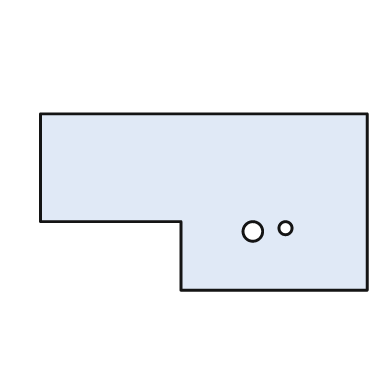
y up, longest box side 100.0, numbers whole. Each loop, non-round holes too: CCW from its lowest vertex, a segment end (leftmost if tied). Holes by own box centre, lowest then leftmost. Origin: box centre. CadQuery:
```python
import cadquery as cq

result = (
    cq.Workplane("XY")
    .moveTo(-7.0, -27.0)
    .lineTo(50.0, -27.0)
    .lineTo(50.0, 27.0)
    .lineTo(-50.0, 27.0)
    .lineTo(-50.0, -6.0)
    .lineTo(-7.0, -6.0)
    .close()
    .moveTo(15.0, -9.0)
    .circle(3.0)
    .moveTo(25.0, -8.0)
    .circle(2.0)
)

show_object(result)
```